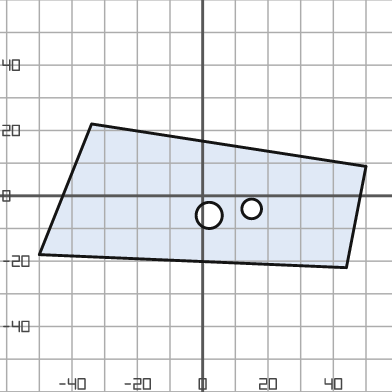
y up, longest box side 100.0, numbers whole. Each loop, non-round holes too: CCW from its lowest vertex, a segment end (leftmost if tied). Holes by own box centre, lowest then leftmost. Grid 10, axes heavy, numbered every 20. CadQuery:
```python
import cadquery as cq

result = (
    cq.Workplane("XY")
    .moveTo(44.0, -22.0)
    .lineTo(50.0, 9.0)
    .lineTo(-34.0, 22.0)
    .lineTo(-50.0, -18.0)
    .close()
    .moveTo(2.0, -6.0)
    .circle(4.0)
    .moveTo(15.0, -4.0)
    .circle(3.0)
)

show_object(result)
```